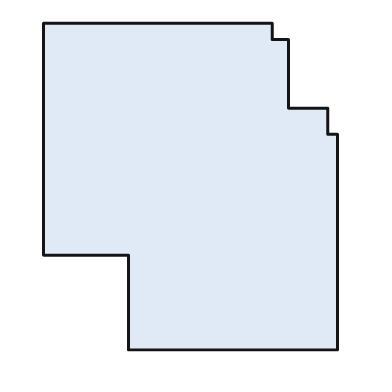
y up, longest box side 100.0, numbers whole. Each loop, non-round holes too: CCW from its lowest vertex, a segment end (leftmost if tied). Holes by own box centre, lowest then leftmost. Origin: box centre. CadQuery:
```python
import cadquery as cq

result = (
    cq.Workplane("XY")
    .moveTo(-19.0, -50.0)
    .lineTo(45.0, -50.0)
    .lineTo(45.0, 16.0)
    .lineTo(42.0, 16.0)
    .lineTo(42.0, 24.0)
    .lineTo(30.0, 24.0)
    .lineTo(30.0, 45.0)
    .lineTo(25.0, 45.0)
    .lineTo(25.0, 50.0)
    .lineTo(-45.0, 50.0)
    .lineTo(-45.0, -21.0)
    .lineTo(-19.0, -21.0)
    .close()
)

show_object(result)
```